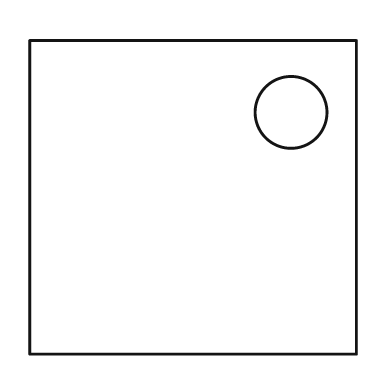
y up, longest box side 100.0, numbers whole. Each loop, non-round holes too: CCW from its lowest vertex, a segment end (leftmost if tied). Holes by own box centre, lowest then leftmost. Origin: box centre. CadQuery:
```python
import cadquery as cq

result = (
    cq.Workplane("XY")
    .moveTo(-50.0, -48.0)
    .lineTo(50.0, -48.0)
    .lineTo(50.0, 48.0)
    .lineTo(-50.0, 48.0)
    .close()
    .moveTo(30.0, 26.0)
    .circle(11.0)
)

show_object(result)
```